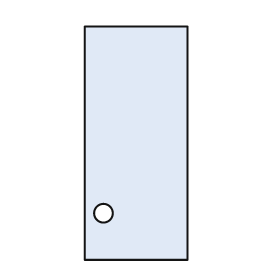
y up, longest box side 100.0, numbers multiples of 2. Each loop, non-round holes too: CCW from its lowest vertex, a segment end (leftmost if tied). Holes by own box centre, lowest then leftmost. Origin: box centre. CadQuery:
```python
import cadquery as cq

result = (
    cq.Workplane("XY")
    .moveTo(-22.0, -50.0)
    .lineTo(22.0, -50.0)
    .lineTo(22.0, 50.0)
    .lineTo(-22.0, 50.0)
    .close()
    .moveTo(-14.0, -30.0)
    .circle(4.0)
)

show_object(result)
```